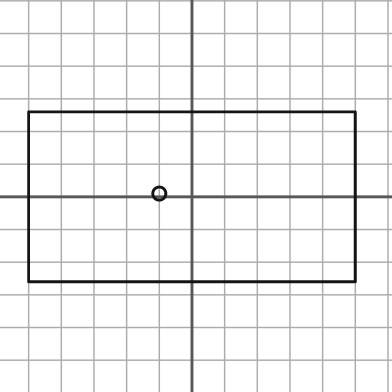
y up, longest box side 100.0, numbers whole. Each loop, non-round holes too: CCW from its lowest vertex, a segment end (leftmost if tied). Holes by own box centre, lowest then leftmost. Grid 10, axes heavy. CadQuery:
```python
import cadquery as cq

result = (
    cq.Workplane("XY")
    .moveTo(-50.0, -26.0)
    .lineTo(50.0, -26.0)
    .lineTo(50.0, 26.0)
    .lineTo(-50.0, 26.0)
    .close()
    .moveTo(-10.0, 1.0)
    .circle(2.0)
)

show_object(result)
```